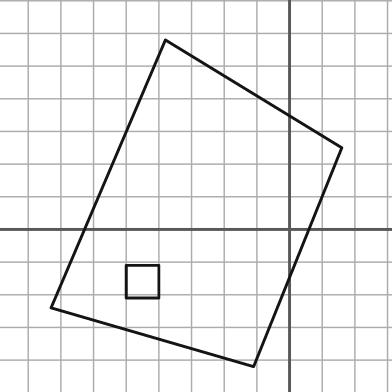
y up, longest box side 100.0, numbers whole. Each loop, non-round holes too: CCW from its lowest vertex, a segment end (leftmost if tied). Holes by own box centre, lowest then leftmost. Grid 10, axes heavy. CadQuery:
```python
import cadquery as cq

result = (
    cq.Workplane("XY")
    .moveTo(-11.0, -42.0)
    .lineTo(16.0, 25.0)
    .lineTo(-38.0, 58.0)
    .lineTo(-73.0, -24.0)
    .close()
    .moveTo(-50.0, -21.0)
    .lineTo(-40.0, -21.0)
    .lineTo(-40.0, -11.0)
    .lineTo(-50.0, -11.0)
    .close()
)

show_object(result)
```